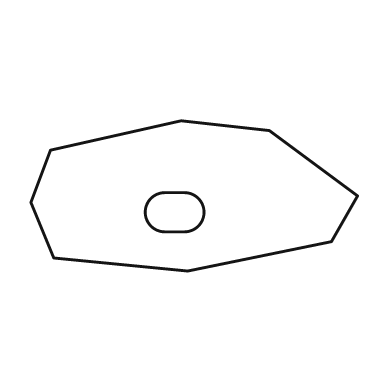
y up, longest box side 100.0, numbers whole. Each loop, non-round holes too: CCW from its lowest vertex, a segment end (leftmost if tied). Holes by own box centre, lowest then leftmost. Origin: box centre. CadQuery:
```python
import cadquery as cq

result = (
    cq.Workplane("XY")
    .moveTo(-2.0, -23.0)
    .lineTo(42.0, -14.0)
    .lineTo(50.0, 0.0)
    .lineTo(23.0, 20.0)
    .lineTo(-4.0, 23.0)
    .lineTo(-44.0, 14.0)
    .lineTo(-50.0, -2.0)
    .lineTo(-43.0, -19.0)
    .close()
    .moveTo(-9.0, -11.0)
    .lineTo(-3.0, -11.0)
    .threePointArc((3.0, -5.0), (-3.0, 1.0))
    .lineTo(-9.0, 1.0)
    .threePointArc((-15.0, -5.0), (-9.0, -11.0))
    .close()
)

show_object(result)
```